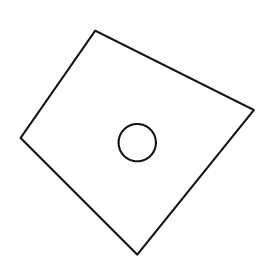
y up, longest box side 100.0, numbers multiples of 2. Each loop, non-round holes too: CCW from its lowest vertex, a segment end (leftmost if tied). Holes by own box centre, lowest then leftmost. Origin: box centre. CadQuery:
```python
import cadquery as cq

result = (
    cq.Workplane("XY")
    .moveTo(0.0, -48.0)
    .lineTo(50.0, 14.0)
    .lineTo(-18.0, 48.0)
    .lineTo(-50.0, 2.0)
    .close()
    .moveTo(0.0, 0.0)
    .circle(8.0)
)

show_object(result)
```